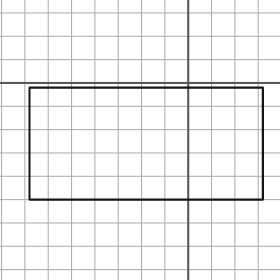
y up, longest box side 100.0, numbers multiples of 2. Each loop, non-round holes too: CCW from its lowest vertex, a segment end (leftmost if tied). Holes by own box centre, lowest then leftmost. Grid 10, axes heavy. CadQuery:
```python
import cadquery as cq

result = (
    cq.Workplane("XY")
    .moveTo(-68.0, -50.0)
    .lineTo(32.0, -50.0)
    .lineTo(32.0, -2.0)
    .lineTo(-68.0, -2.0)
    .close()
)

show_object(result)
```